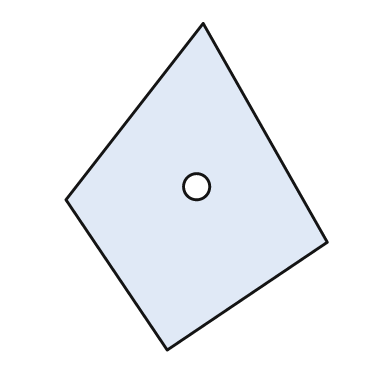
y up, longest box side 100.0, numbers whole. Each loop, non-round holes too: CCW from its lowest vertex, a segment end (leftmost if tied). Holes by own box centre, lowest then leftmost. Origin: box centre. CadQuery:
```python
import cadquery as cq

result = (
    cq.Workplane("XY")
    .moveTo(-9.0, -50.0)
    .lineTo(40.0, -17.0)
    .lineTo(2.0, 50.0)
    .lineTo(-40.0, -4.0)
    .close()
    .moveTo(0.0, 0.0)
    .circle(4.0)
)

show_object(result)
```